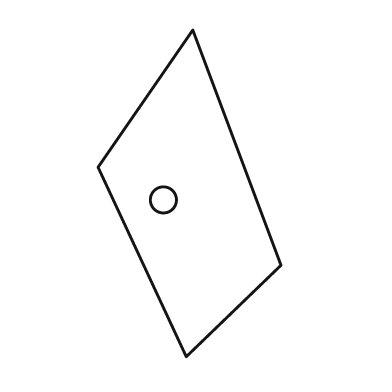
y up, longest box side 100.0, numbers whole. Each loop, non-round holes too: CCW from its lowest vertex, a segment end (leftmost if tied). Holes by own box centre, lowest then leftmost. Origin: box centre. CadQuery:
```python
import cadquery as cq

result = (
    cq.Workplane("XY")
    .moveTo(-1.0, -50.0)
    .lineTo(28.0, -22.0)
    .lineTo(1.0, 50.0)
    .lineTo(-28.0, 8.0)
    .close()
    .moveTo(-8.0, -2.0)
    .circle(4.0)
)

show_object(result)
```